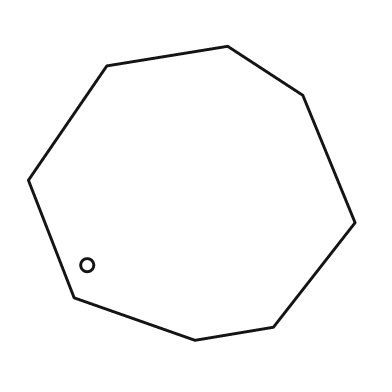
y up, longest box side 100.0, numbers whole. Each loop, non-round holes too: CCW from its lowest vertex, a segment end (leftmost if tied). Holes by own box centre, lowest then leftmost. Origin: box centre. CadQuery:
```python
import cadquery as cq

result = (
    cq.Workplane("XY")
    .moveTo(1.0, -45.0)
    .lineTo(25.0, -41.0)
    .lineTo(50.0, -9.0)
    .lineTo(34.0, 30.0)
    .lineTo(11.0, 45.0)
    .lineTo(-26.0, 39.0)
    .lineTo(-50.0, 4.0)
    .lineTo(-36.0, -32.0)
    .close()
    .moveTo(-32.0, -22.0)
    .circle(2.0)
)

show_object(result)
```